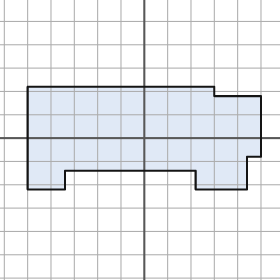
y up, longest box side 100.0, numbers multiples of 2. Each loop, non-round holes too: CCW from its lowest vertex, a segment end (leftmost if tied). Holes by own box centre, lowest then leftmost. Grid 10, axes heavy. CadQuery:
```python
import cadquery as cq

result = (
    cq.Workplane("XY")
    .moveTo(-50.0, -22.0)
    .lineTo(-34.0, -22.0)
    .lineTo(-34.0, -14.0)
    .lineTo(22.0, -14.0)
    .lineTo(22.0, -22.0)
    .lineTo(44.0, -22.0)
    .lineTo(44.0, -8.0)
    .lineTo(50.0, -8.0)
    .lineTo(50.0, 18.0)
    .lineTo(30.0, 18.0)
    .lineTo(30.0, 22.0)
    .lineTo(-50.0, 22.0)
    .close()
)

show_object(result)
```